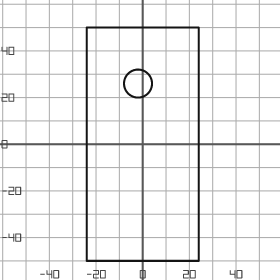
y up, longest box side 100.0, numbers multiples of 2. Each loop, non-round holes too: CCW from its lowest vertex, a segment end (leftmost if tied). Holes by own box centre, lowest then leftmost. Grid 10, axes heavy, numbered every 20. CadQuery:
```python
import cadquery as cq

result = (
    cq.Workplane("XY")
    .moveTo(-24.0, -50.0)
    .lineTo(24.0, -50.0)
    .lineTo(24.0, 50.0)
    .lineTo(-24.0, 50.0)
    .close()
    .moveTo(-2.0, 26.0)
    .circle(6.0)
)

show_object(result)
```